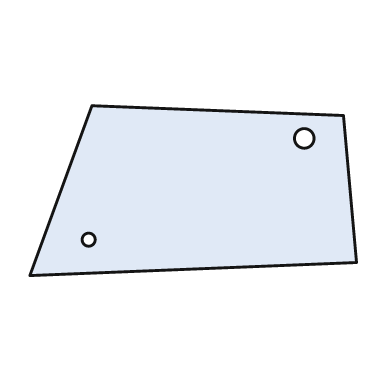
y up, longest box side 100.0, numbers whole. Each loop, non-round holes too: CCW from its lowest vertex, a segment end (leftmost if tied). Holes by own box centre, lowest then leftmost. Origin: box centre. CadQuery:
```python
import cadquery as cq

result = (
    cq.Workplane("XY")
    .moveTo(-50.0, -26.0)
    .lineTo(50.0, -22.0)
    .lineTo(46.0, 23.0)
    .lineTo(-31.0, 26.0)
    .close()
    .moveTo(-32.0, -15.0)
    .circle(2.0)
    .moveTo(34.0, 16.0)
    .circle(3.0)
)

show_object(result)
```